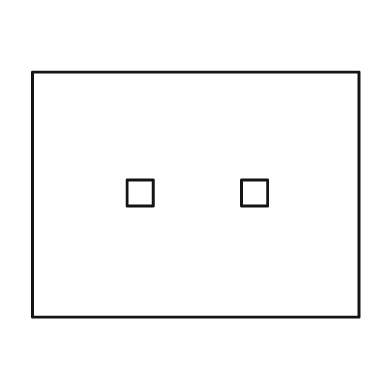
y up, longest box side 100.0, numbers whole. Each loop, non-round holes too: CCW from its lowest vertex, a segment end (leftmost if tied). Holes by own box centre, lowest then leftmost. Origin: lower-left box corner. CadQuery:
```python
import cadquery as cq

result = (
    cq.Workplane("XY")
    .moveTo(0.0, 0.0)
    .lineTo(100.0, 0.0)
    .lineTo(100.0, 75.0)
    .lineTo(0.0, 75.0)
    .close()
    .moveTo(29.0, 34.0)
    .lineTo(37.0, 34.0)
    .lineTo(37.0, 42.0)
    .lineTo(29.0, 42.0)
    .close()
    .moveTo(64.0, 34.0)
    .lineTo(72.0, 34.0)
    .lineTo(72.0, 42.0)
    .lineTo(64.0, 42.0)
    .close()
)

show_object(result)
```